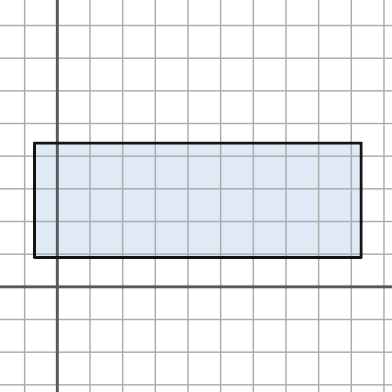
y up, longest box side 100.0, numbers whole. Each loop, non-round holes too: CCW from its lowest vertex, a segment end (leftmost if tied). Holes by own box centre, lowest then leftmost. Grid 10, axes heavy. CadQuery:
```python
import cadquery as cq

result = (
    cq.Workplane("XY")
    .moveTo(-7.0, 9.0)
    .lineTo(93.0, 9.0)
    .lineTo(93.0, 44.0)
    .lineTo(-7.0, 44.0)
    .close()
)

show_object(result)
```